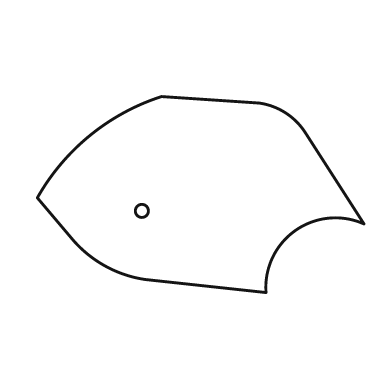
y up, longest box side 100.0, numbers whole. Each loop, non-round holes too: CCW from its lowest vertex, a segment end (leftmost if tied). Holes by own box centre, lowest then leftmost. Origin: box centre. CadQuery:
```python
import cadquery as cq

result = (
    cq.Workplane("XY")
    .moveTo(20.0, -30.0)
    .threePointArc((29.0, -11.0), (50.0, -9.0))
    .lineTo(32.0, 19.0)
    .threePointArc((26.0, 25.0), (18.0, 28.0))
    .lineTo(-12.0, 30.0)
    .threePointArc((-34.0, 18.0), (-50.0, -1.0))
    .lineTo(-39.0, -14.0)
    .threePointArc((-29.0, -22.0), (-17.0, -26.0))
    .close()
    .moveTo(-18.0, -5.0)
    .circle(2.0)
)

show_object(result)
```